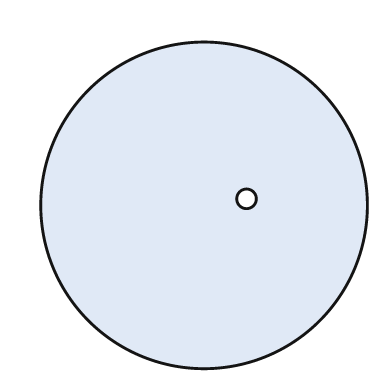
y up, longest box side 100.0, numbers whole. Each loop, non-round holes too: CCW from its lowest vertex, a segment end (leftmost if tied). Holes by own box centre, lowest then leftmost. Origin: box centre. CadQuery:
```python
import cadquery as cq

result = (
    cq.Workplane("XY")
    .moveTo(0.0, 0.0)
    .circle(50.0)
    .moveTo(13.0, 2.0)
    .circle(3.0)
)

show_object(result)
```